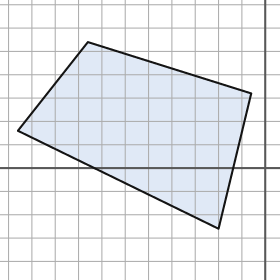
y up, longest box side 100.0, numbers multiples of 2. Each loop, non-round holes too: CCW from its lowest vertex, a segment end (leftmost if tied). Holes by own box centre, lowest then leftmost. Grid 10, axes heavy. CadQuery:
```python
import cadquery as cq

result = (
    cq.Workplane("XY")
    .moveTo(-20.0, -26.0)
    .lineTo(-6.0, 32.0)
    .lineTo(-76.0, 54.0)
    .lineTo(-106.0, 16.0)
    .close()
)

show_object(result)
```